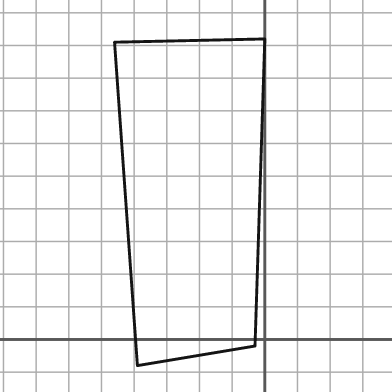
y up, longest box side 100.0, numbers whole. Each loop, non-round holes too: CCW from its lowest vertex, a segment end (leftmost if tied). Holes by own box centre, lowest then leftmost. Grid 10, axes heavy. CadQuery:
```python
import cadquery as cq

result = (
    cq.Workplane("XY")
    .moveTo(-39.0, -8.0)
    .lineTo(-3.0, -2.0)
    .lineTo(0.0, 92.0)
    .lineTo(-46.0, 91.0)
    .close()
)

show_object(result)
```